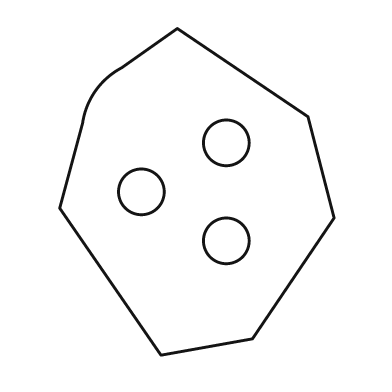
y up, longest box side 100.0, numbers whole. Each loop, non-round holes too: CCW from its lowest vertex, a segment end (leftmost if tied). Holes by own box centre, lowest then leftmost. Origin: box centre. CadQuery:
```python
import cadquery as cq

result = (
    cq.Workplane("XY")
    .moveTo(-11.0, -50.0)
    .lineTo(17.0, -45.0)
    .lineTo(42.0, -8.0)
    .lineTo(34.0, 23.0)
    .lineTo(-6.0, 50.0)
    .lineTo(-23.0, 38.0)
    .threePointArc((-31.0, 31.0), (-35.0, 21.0))
    .lineTo(-42.0, -5.0)
    .close()
    .moveTo(9.0, -15.0)
    .circle(7.0)
    .moveTo(-17.0, 0.0)
    .circle(7.0)
    .moveTo(9.0, 15.0)
    .circle(7.0)
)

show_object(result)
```